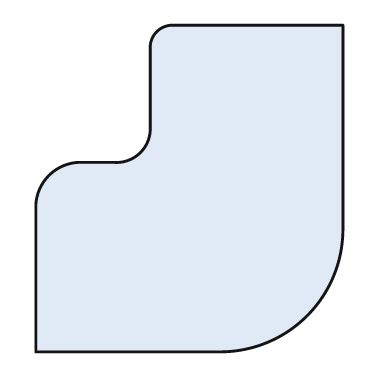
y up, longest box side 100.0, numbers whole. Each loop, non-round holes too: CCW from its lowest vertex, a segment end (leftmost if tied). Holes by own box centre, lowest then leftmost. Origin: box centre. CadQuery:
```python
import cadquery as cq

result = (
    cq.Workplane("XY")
    .moveTo(-47.0, -50.0)
    .lineTo(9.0, -50.0)
    .threePointArc((36.0, -39.0), (47.0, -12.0))
    .lineTo(47.0, 50.0)
    .lineTo(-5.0, 50.0)
    .threePointArc((-10.0, 48.0), (-12.0, 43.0))
    .lineTo(-12.0, 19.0)
    .threePointArc((-15.0, 11.0), (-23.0, 8.0))
    .lineTo(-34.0, 8.0)
    .threePointArc((-43.0, 4.0), (-47.0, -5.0))
    .close()
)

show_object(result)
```